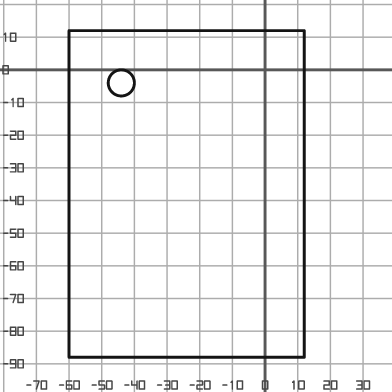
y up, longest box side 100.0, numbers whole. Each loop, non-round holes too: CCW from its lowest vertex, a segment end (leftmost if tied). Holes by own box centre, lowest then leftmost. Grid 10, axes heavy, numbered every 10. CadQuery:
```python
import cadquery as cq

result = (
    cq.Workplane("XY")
    .moveTo(-60.0, -88.0)
    .lineTo(12.0, -88.0)
    .lineTo(12.0, 12.0)
    .lineTo(-60.0, 12.0)
    .close()
    .moveTo(-44.0, -4.0)
    .circle(4.0)
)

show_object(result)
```